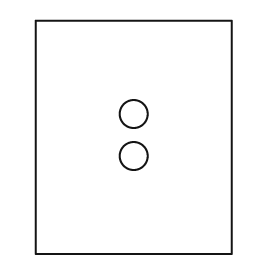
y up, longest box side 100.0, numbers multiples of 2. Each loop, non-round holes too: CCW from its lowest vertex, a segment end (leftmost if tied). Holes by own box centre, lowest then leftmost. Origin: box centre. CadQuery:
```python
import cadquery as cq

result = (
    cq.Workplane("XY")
    .moveTo(-42.0, -50.0)
    .lineTo(42.0, -50.0)
    .lineTo(42.0, 50.0)
    .lineTo(-42.0, 50.0)
    .close()
    .moveTo(0.0, -8.0)
    .circle(6.0)
    .moveTo(0.0, 10.0)
    .circle(6.0)
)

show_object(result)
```